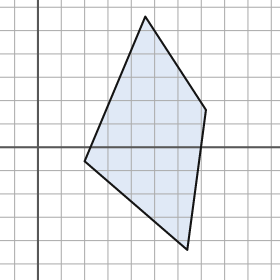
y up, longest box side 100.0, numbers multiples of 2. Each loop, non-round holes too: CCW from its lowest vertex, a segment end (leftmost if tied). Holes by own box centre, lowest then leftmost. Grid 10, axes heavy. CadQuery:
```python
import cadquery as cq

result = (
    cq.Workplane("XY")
    .moveTo(64.0, -44.0)
    .lineTo(72.0, 16.0)
    .lineTo(46.0, 56.0)
    .lineTo(20.0, -6.0)
    .close()
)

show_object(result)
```